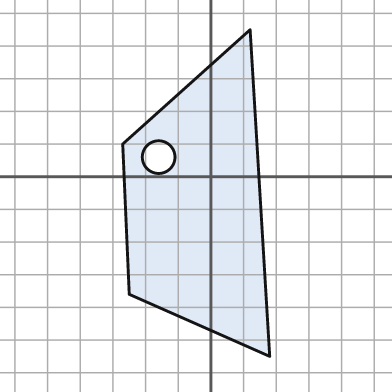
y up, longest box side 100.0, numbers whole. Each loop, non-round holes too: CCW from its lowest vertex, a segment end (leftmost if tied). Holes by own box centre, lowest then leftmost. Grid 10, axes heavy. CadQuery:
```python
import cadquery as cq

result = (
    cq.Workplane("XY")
    .moveTo(18.0, -55.0)
    .lineTo(12.0, 45.0)
    .lineTo(-27.0, 10.0)
    .lineTo(-25.0, -36.0)
    .close()
    .moveTo(-16.0, 6.0)
    .circle(5.0)
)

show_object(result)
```